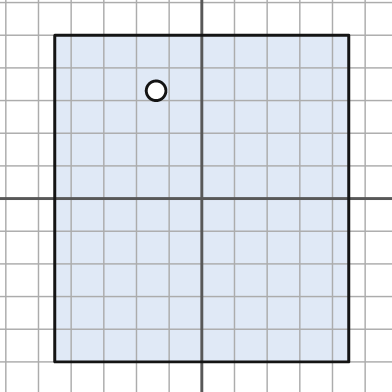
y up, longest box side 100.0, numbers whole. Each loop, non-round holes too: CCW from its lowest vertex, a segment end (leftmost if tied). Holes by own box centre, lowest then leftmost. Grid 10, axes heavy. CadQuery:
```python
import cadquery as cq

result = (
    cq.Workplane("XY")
    .moveTo(-45.0, -50.0)
    .lineTo(45.0, -50.0)
    .lineTo(45.0, 50.0)
    .lineTo(-45.0, 50.0)
    .close()
    .moveTo(-14.0, 33.0)
    .circle(3.0)
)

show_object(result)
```